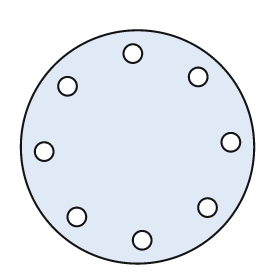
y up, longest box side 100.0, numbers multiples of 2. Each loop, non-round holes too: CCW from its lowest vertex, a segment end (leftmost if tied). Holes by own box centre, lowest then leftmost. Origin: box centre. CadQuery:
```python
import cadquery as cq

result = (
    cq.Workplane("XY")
    .moveTo(0.0, 0.0)
    .circle(50.0)
    .moveTo(2.0, -40.0)
    .circle(4.0)
    .moveTo(-26.0, -30.0)
    .circle(4.0)
    .moveTo(30.0, -26.0)
    .circle(4.0)
    .moveTo(-40.0, -2.0)
    .circle(4.0)
    .moveTo(40.0, 2.0)
    .circle(4.0)
    .moveTo(-30.0, 26.0)
    .circle(4.0)
    .moveTo(26.0, 30.0)
    .circle(4.0)
    .moveTo(-2.0, 40.0)
    .circle(4.0)
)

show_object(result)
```